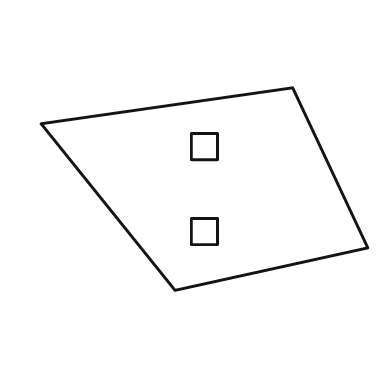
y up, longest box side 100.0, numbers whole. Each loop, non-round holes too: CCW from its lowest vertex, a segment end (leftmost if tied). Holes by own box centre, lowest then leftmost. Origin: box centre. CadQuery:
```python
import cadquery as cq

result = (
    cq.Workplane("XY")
    .moveTo(-9.0, -31.0)
    .lineTo(50.0, -18.0)
    .lineTo(27.0, 31.0)
    .lineTo(-50.0, 20.0)
    .close()
    .moveTo(-4.0, -17.0)
    .lineTo(4.0, -17.0)
    .lineTo(4.0, -9.0)
    .lineTo(-4.0, -9.0)
    .close()
    .moveTo(-4.0, 9.0)
    .lineTo(4.0, 9.0)
    .lineTo(4.0, 17.0)
    .lineTo(-4.0, 17.0)
    .close()
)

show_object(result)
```